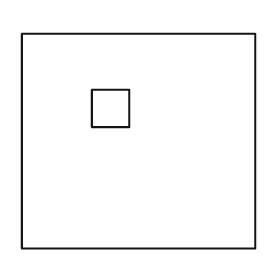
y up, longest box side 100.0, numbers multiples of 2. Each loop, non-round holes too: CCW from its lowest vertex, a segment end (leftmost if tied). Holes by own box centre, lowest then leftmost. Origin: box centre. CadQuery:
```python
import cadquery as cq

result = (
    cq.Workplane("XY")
    .moveTo(-50.0, -46.0)
    .lineTo(50.0, -46.0)
    .lineTo(50.0, 46.0)
    .lineTo(-50.0, 46.0)
    .close()
    .moveTo(-20.0, 6.0)
    .lineTo(-4.0, 6.0)
    .lineTo(-4.0, 22.0)
    .lineTo(-20.0, 22.0)
    .close()
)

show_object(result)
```